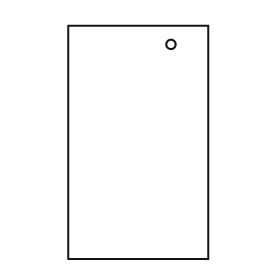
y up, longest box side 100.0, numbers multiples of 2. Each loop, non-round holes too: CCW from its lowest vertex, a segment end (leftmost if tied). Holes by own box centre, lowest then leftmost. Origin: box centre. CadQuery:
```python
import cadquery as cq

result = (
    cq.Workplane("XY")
    .moveTo(-30.0, -50.0)
    .lineTo(30.0, -50.0)
    .lineTo(30.0, 50.0)
    .lineTo(-30.0, 50.0)
    .close()
    .moveTo(14.0, 42.0)
    .circle(2.0)
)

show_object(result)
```